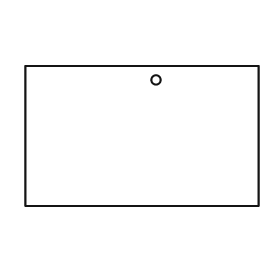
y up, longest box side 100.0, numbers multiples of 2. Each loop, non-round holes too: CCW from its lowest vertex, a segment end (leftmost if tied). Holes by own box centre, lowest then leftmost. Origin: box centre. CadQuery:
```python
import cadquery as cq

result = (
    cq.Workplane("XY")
    .moveTo(-50.0, -30.0)
    .lineTo(50.0, -30.0)
    .lineTo(50.0, 30.0)
    .lineTo(-50.0, 30.0)
    .close()
    .moveTo(6.0, 24.0)
    .circle(2.0)
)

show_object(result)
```